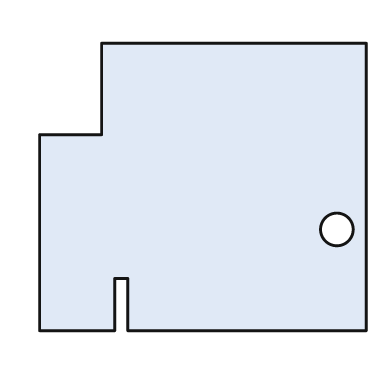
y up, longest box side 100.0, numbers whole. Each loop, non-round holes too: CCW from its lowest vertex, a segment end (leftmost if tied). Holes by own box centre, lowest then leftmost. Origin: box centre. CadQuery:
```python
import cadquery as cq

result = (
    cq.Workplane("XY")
    .moveTo(-50.0, -44.0)
    .lineTo(-27.0, -44.0)
    .lineTo(-27.0, -28.0)
    .lineTo(-23.0, -28.0)
    .lineTo(-23.0, -44.0)
    .lineTo(50.0, -44.0)
    .lineTo(50.0, 44.0)
    .lineTo(-31.0, 44.0)
    .lineTo(-31.0, 16.0)
    .lineTo(-50.0, 16.0)
    .close()
    .moveTo(41.0, -13.0)
    .circle(5.0)
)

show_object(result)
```